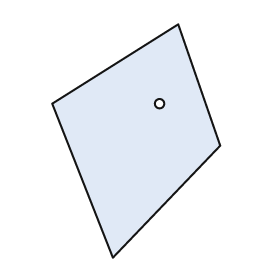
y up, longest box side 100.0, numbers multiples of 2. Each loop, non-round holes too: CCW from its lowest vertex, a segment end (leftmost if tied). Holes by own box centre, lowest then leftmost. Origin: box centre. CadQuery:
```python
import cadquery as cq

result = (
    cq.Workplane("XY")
    .moveTo(-10.0, -50.0)
    .lineTo(36.0, -2.0)
    .lineTo(18.0, 50.0)
    .lineTo(-36.0, 16.0)
    .close()
    .moveTo(10.0, 16.0)
    .circle(2.0)
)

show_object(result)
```